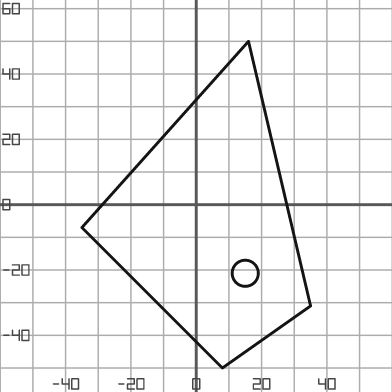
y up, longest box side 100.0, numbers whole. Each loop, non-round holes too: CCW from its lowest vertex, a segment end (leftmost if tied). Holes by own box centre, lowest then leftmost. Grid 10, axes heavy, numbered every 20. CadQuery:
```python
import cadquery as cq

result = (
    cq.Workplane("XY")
    .moveTo(8.0, -50.0)
    .lineTo(35.0, -31.0)
    .lineTo(16.0, 50.0)
    .lineTo(-35.0, -7.0)
    .close()
    .moveTo(15.0, -21.0)
    .circle(4.0)
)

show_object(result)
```